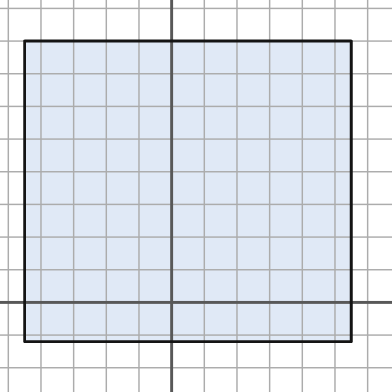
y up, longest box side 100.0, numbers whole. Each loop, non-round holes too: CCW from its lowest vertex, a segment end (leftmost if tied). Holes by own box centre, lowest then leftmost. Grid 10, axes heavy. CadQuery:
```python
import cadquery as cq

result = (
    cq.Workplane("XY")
    .moveTo(-45.0, -12.0)
    .lineTo(55.0, -12.0)
    .lineTo(55.0, 80.0)
    .lineTo(-45.0, 80.0)
    .close()
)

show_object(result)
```